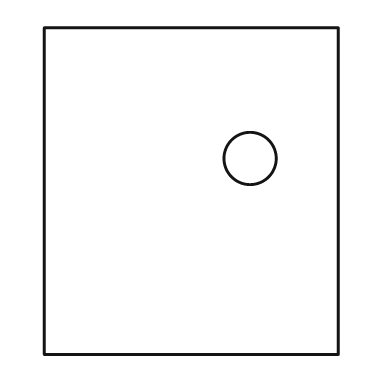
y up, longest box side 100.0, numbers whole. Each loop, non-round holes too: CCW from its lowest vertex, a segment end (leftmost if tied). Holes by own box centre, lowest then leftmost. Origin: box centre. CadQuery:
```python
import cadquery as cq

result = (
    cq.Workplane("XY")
    .moveTo(-45.0, -50.0)
    .lineTo(45.0, -50.0)
    .lineTo(45.0, 50.0)
    .lineTo(-45.0, 50.0)
    .close()
    .moveTo(18.0, 10.0)
    .circle(8.0)
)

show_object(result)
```